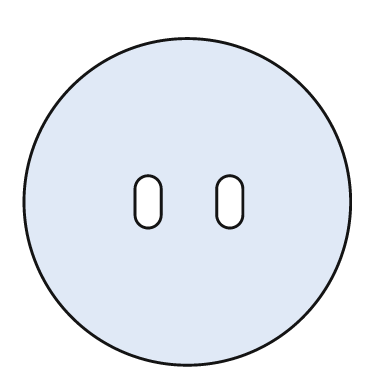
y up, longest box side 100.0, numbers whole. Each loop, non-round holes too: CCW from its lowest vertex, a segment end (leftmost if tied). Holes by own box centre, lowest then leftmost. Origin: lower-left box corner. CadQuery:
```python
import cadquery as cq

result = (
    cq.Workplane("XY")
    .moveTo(50.0, 50.0)
    .circle(50.0)
    .moveTo(34.0, 46.0)
    .threePointArc((38.0, 42.0), (42.0, 46.0))
    .lineTo(42.0, 54.0)
    .threePointArc((38.0, 58.0), (34.0, 54.0))
    .close()
    .moveTo(59.0, 46.0)
    .threePointArc((63.0, 42.0), (67.0, 46.0))
    .lineTo(67.0, 54.0)
    .threePointArc((63.0, 58.0), (59.0, 54.0))
    .close()
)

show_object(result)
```